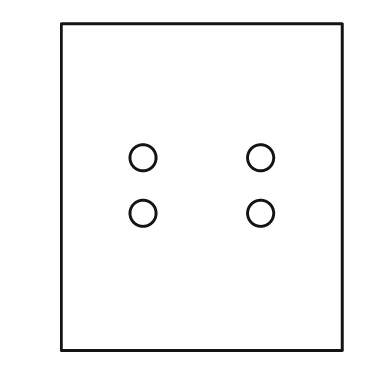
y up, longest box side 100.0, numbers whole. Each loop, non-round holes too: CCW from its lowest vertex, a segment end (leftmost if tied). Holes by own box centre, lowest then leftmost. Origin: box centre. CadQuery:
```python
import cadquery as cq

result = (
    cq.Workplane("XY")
    .moveTo(-43.0, -50.0)
    .lineTo(43.0, -50.0)
    .lineTo(43.0, 50.0)
    .lineTo(-43.0, 50.0)
    .close()
    .moveTo(-18.0, -8.0)
    .circle(4.0)
    .moveTo(18.0, -8.0)
    .circle(4.0)
    .moveTo(-18.0, 9.0)
    .circle(4.0)
    .moveTo(18.0, 9.0)
    .circle(4.0)
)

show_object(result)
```